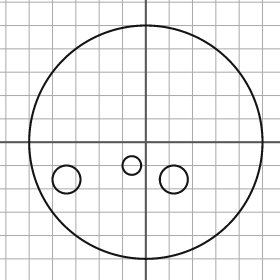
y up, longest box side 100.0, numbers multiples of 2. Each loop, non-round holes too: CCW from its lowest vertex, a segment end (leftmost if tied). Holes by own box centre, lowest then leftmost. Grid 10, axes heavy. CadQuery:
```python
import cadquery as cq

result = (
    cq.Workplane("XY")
    .moveTo(0.0, 0.0)
    .circle(50.0)
    .moveTo(-34.0, -16.0)
    .circle(6.0)
    .moveTo(12.0, -16.0)
    .circle(6.0)
    .moveTo(-6.0, -10.0)
    .circle(4.0)
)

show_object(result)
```